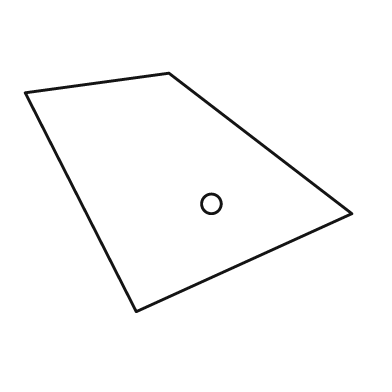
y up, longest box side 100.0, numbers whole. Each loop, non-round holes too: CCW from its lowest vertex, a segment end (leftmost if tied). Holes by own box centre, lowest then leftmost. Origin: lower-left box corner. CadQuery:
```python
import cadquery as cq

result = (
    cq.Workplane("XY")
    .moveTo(34.0, 0.0)
    .lineTo(100.0, 30.0)
    .lineTo(44.0, 73.0)
    .lineTo(0.0, 67.0)
    .close()
    .moveTo(57.0, 33.0)
    .circle(3.0)
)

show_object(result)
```